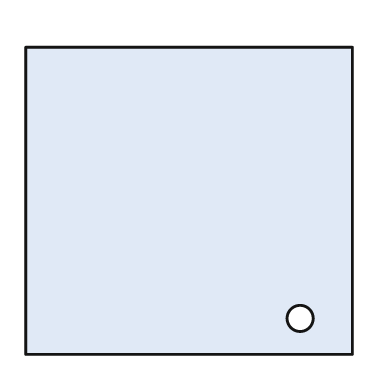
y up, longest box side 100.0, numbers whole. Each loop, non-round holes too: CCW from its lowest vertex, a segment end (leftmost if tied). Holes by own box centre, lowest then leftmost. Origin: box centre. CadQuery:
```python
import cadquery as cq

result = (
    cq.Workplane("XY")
    .moveTo(-50.0, -47.0)
    .lineTo(50.0, -47.0)
    .lineTo(50.0, 47.0)
    .lineTo(-50.0, 47.0)
    .close()
    .moveTo(34.0, -36.0)
    .circle(4.0)
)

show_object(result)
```